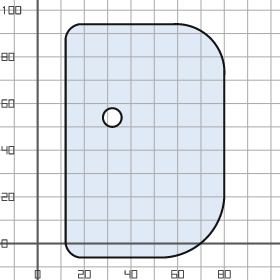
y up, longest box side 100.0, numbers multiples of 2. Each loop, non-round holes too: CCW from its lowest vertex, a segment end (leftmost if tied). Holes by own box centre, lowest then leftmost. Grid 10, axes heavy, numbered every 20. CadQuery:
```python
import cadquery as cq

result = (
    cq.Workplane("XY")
    .moveTo(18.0, -6.0)
    .lineTo(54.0, -6.0)
    .threePointArc((72.0, 2.0), (80.0, 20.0))
    .lineTo(80.0, 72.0)
    .threePointArc((74.0, 88.0), (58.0, 94.0))
    .lineTo(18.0, 94.0)
    .threePointArc((14.0, 92.0), (12.0, 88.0))
    .lineTo(12.0, 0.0)
    .threePointArc((14.0, -4.0), (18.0, -6.0))
    .close()
    .moveTo(32.0, 54.0)
    .circle(4.0)
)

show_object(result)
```